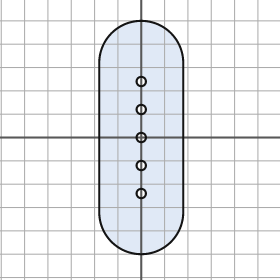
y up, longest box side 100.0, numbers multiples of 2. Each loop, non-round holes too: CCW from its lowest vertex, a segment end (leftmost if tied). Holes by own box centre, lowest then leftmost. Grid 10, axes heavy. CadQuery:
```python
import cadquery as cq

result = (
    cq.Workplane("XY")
    .moveTo(-18.0, -32.0)
    .threePointArc((0.0, -50.0), (18.0, -32.0))
    .lineTo(18.0, 32.0)
    .threePointArc((0.0, 50.0), (-18.0, 32.0))
    .close()
    .moveTo(0.0, -24.0)
    .circle(2.0)
    .moveTo(0.0, -12.0)
    .circle(2.0)
    .moveTo(0.0, 0.0)
    .circle(2.0)
    .moveTo(0.0, 12.0)
    .circle(2.0)
    .moveTo(0.0, 24.0)
    .circle(2.0)
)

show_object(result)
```